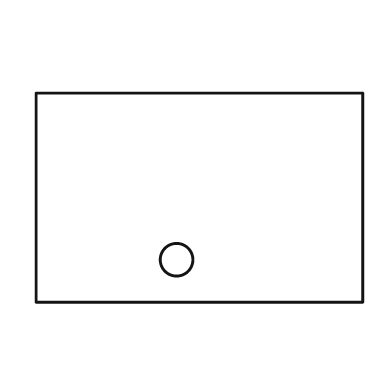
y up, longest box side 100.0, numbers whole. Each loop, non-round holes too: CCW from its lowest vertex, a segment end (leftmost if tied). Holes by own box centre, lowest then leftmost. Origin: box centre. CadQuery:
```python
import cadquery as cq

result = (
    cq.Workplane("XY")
    .moveTo(-50.0, -32.0)
    .lineTo(50.0, -32.0)
    .lineTo(50.0, 32.0)
    .lineTo(-50.0, 32.0)
    .close()
    .moveTo(-7.0, -19.0)
    .circle(5.0)
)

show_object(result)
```